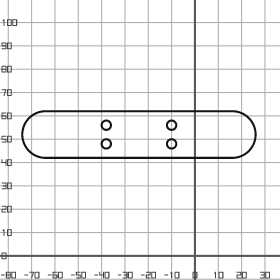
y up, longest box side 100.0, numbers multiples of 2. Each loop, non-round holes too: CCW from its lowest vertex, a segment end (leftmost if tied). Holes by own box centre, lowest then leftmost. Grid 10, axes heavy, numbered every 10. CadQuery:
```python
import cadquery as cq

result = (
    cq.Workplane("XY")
    .moveTo(-64.0, 42.0)
    .lineTo(16.0, 42.0)
    .threePointArc((26.0, 52.0), (16.0, 62.0))
    .lineTo(-64.0, 62.0)
    .threePointArc((-74.0, 52.0), (-64.0, 42.0))
    .close()
    .moveTo(-38.0, 48.0)
    .circle(2.0)
    .moveTo(-10.0, 48.0)
    .circle(2.0)
    .moveTo(-38.0, 56.0)
    .circle(2.0)
    .moveTo(-10.0, 56.0)
    .circle(2.0)
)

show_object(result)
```